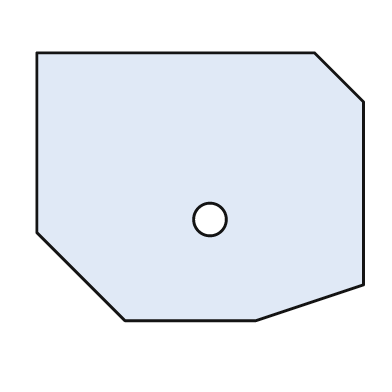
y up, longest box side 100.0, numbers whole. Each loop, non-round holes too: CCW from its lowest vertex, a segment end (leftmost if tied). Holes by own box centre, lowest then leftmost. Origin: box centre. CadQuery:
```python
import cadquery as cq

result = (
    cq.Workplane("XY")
    .moveTo(-23.0, -41.0)
    .lineTo(17.0, -41.0)
    .lineTo(50.0, -30.0)
    .lineTo(50.0, 26.0)
    .lineTo(35.0, 41.0)
    .lineTo(-50.0, 41.0)
    .lineTo(-50.0, -14.0)
    .close()
    .moveTo(3.0, -10.0)
    .circle(5.0)
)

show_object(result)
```